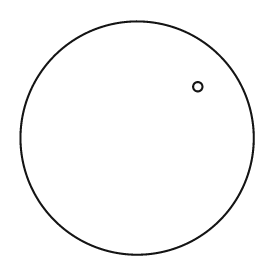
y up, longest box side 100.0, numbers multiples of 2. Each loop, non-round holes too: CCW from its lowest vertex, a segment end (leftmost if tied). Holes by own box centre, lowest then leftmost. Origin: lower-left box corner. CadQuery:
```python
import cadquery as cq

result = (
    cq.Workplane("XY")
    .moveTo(50.0, 50.0)
    .circle(50.0)
    .moveTo(76.0, 72.0)
    .circle(2.0)
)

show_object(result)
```